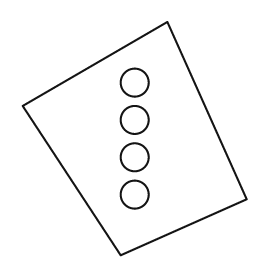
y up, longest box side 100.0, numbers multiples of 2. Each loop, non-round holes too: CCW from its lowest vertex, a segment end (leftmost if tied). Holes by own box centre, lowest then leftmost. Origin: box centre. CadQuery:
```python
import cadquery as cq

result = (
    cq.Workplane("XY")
    .moveTo(-6.0, -50.0)
    .lineTo(48.0, -26.0)
    .lineTo(14.0, 50.0)
    .lineTo(-48.0, 14.0)
    .close()
    .moveTo(0.0, -24.0)
    .circle(6.0)
    .moveTo(0.0, -8.0)
    .circle(6.0)
    .moveTo(0.0, 8.0)
    .circle(6.0)
    .moveTo(0.0, 24.0)
    .circle(6.0)
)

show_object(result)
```